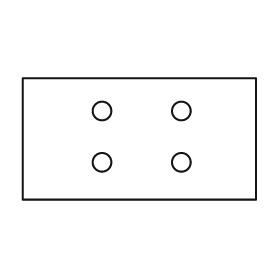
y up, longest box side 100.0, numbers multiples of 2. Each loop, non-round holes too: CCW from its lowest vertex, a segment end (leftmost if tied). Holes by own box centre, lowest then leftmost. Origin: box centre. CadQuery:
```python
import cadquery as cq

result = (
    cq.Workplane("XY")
    .moveTo(-50.0, -26.0)
    .lineTo(50.0, -26.0)
    .lineTo(50.0, 26.0)
    .lineTo(-50.0, 26.0)
    .close()
    .moveTo(-16.0, -10.0)
    .circle(4.0)
    .moveTo(18.0, -10.0)
    .circle(4.0)
    .moveTo(-16.0, 12.0)
    .circle(4.0)
    .moveTo(18.0, 12.0)
    .circle(4.0)
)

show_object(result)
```